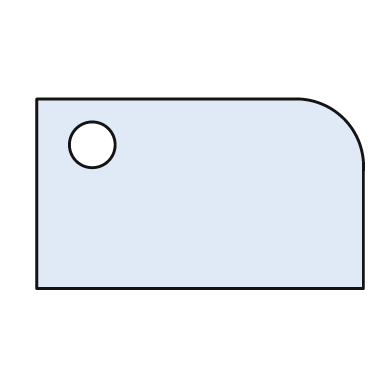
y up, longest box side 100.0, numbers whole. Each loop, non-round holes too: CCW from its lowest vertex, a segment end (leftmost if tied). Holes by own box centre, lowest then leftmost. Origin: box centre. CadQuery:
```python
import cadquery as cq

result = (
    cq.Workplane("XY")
    .moveTo(-50.0, -29.0)
    .lineTo(50.0, -29.0)
    .lineTo(50.0, 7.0)
    .threePointArc((44.0, 23.0), (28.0, 29.0))
    .lineTo(-50.0, 29.0)
    .close()
    .moveTo(-33.0, 15.0)
    .circle(7.0)
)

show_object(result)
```